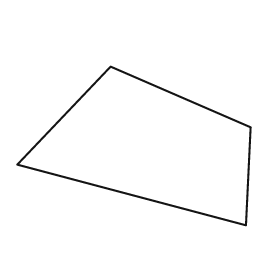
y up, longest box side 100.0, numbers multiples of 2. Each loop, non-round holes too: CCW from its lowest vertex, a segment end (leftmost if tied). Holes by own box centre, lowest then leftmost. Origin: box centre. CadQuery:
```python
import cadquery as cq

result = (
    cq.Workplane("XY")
    .moveTo(48.0, -34.0)
    .lineTo(50.0, 8.0)
    .lineTo(-10.0, 34.0)
    .lineTo(-50.0, -8.0)
    .close()
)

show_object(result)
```